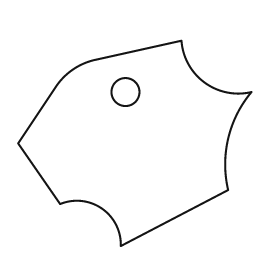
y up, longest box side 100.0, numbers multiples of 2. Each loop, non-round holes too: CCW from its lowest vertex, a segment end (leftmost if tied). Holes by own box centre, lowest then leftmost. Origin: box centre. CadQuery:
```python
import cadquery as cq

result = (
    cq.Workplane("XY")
    .moveTo(-6.0, -44.0)
    .lineTo(40.0, -20.0)
    .threePointArc((40.0, 2.0), (50.0, 22.0))
    .threePointArc((30.0, 26.0), (20.0, 44.0))
    .lineTo(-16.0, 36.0)
    .threePointArc((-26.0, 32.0), (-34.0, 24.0))
    .lineTo(-50.0, 0.0)
    .lineTo(-32.0, -26.0)
    .threePointArc((-14.0, -28.0), (-6.0, -44.0))
    .close()
    .moveTo(-4.0, 22.0)
    .circle(6.0)
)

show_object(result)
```